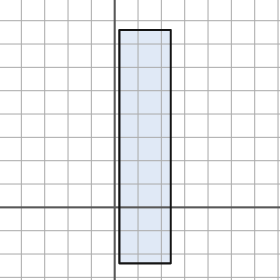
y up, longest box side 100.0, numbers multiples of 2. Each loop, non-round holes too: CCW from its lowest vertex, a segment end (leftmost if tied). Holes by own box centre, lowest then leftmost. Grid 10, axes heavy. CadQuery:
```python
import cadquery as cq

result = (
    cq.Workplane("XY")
    .moveTo(2.0, -24.0)
    .lineTo(24.0, -24.0)
    .lineTo(24.0, 76.0)
    .lineTo(2.0, 76.0)
    .close()
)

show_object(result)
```